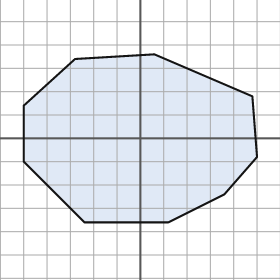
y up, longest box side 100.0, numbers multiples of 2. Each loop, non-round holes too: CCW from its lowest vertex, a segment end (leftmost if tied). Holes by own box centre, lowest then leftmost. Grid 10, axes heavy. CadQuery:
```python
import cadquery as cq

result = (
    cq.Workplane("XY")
    .moveTo(-24.0, -36.0)
    .lineTo(12.0, -36.0)
    .lineTo(36.0, -24.0)
    .lineTo(50.0, -8.0)
    .lineTo(48.0, 18.0)
    .lineTo(6.0, 36.0)
    .lineTo(-28.0, 34.0)
    .lineTo(-50.0, 14.0)
    .lineTo(-50.0, -10.0)
    .close()
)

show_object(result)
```